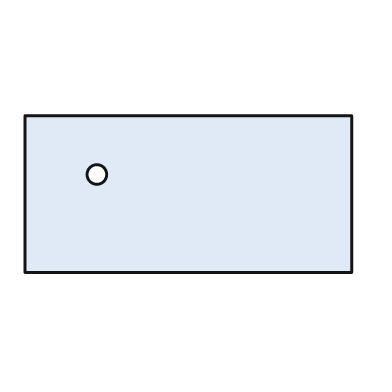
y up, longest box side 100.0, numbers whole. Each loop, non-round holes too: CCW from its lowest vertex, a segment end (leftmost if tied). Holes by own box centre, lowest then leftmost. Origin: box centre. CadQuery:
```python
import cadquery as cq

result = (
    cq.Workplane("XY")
    .moveTo(-50.0, -24.0)
    .lineTo(50.0, -24.0)
    .lineTo(50.0, 24.0)
    .lineTo(-50.0, 24.0)
    .close()
    .moveTo(-28.0, 6.0)
    .circle(3.0)
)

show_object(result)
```